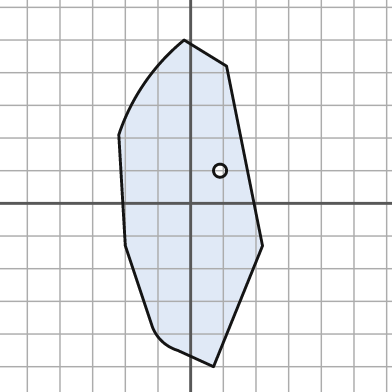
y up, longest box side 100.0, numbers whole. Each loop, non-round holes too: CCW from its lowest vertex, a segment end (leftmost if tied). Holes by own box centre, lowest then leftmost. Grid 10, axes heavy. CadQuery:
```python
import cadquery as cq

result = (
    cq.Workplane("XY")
    .moveTo(7.0, -50.0)
    .lineTo(22.0, -13.0)
    .lineTo(11.0, 42.0)
    .lineTo(-2.0, 50.0)
    .threePointArc((-14.0, 37.0), (-22.0, 21.0))
    .lineTo(-20.0, -13.0)
    .lineTo(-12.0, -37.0)
    .threePointArc((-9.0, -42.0), (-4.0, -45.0))
    .close()
    .moveTo(9.0, 10.0)
    .circle(2.0)
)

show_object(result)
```